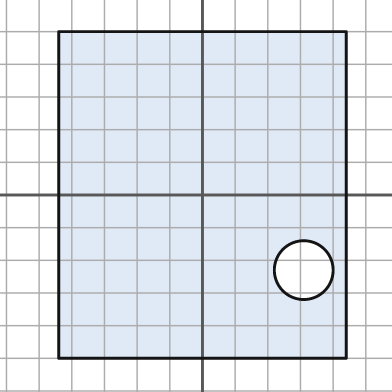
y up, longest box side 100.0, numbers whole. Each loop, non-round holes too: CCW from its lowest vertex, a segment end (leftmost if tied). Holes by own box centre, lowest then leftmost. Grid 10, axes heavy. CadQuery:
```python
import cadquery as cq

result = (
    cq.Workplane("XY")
    .moveTo(-44.0, -50.0)
    .lineTo(44.0, -50.0)
    .lineTo(44.0, 50.0)
    .lineTo(-44.0, 50.0)
    .close()
    .moveTo(31.0, -23.0)
    .circle(9.0)
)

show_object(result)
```